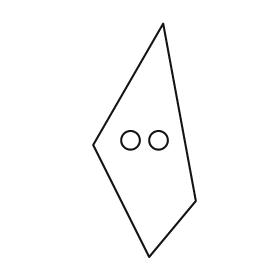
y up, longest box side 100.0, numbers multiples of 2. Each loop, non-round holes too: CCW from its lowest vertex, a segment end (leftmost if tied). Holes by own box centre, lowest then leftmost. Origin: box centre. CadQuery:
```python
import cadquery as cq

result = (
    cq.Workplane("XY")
    .moveTo(2.0, -50.0)
    .lineTo(22.0, -26.0)
    .lineTo(8.0, 50.0)
    .lineTo(-22.0, -2.0)
    .close()
    .moveTo(-6.0, 0.0)
    .circle(4.0)
    .moveTo(6.0, 0.0)
    .circle(4.0)
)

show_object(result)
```